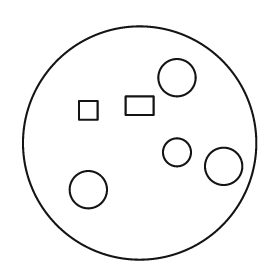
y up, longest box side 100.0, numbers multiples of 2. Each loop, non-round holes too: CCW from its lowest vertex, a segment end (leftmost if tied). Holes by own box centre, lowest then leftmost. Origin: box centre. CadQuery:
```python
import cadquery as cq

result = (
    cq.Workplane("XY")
    .moveTo(0.0, 0.0)
    .circle(50.0)
    .moveTo(-22.0, -20.0)
    .circle(8.0)
    .moveTo(36.0, -10.0)
    .circle(8.0)
    .moveTo(16.0, -4.0)
    .circle(6.0)
    .moveTo(-26.0, 10.0)
    .lineTo(-18.0, 10.0)
    .lineTo(-18.0, 18.0)
    .lineTo(-26.0, 18.0)
    .close()
    .moveTo(-6.0, 12.0)
    .lineTo(6.0, 12.0)
    .lineTo(6.0, 20.0)
    .lineTo(-6.0, 20.0)
    .close()
    .moveTo(16.0, 28.0)
    .circle(8.0)
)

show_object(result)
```